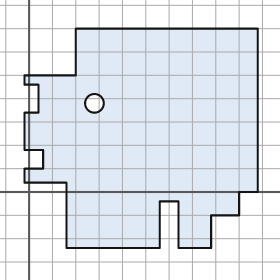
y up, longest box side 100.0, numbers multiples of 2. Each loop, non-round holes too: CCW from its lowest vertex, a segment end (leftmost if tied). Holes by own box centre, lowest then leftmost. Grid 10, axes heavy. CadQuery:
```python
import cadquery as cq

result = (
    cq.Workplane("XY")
    .moveTo(16.0, -24.0)
    .lineTo(56.0, -24.0)
    .lineTo(56.0, -4.0)
    .lineTo(64.0, -4.0)
    .lineTo(64.0, -24.0)
    .lineTo(78.0, -24.0)
    .lineTo(78.0, -10.0)
    .lineTo(90.0, -10.0)
    .lineTo(90.0, 0.0)
    .lineTo(98.0, 0.0)
    .lineTo(98.0, 70.0)
    .lineTo(20.0, 70.0)
    .lineTo(20.0, 50.0)
    .lineTo(-2.0, 50.0)
    .lineTo(-2.0, 46.0)
    .lineTo(4.0, 46.0)
    .lineTo(4.0, 34.0)
    .lineTo(-2.0, 34.0)
    .lineTo(-2.0, 18.0)
    .lineTo(6.0, 18.0)
    .lineTo(6.0, 10.0)
    .lineTo(-2.0, 10.0)
    .lineTo(-2.0, 4.0)
    .lineTo(16.0, 4.0)
    .close()
    .moveTo(28.0, 38.0)
    .circle(4.0)
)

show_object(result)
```